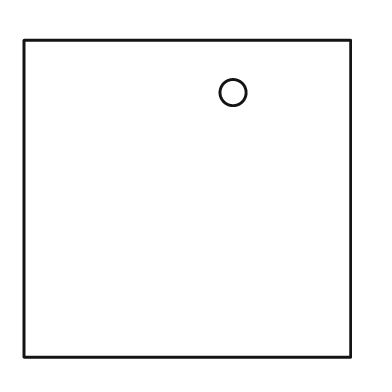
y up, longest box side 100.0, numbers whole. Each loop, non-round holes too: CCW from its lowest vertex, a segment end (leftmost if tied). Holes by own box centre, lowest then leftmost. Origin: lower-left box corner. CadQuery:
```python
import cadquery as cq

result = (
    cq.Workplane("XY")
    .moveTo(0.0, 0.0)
    .lineTo(100.0, 0.0)
    .lineTo(100.0, 97.0)
    .lineTo(0.0, 97.0)
    .close()
    .moveTo(64.0, 81.0)
    .circle(4.0)
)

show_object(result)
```